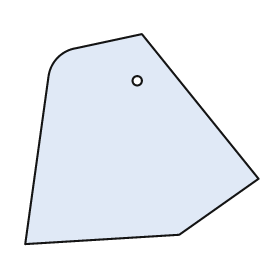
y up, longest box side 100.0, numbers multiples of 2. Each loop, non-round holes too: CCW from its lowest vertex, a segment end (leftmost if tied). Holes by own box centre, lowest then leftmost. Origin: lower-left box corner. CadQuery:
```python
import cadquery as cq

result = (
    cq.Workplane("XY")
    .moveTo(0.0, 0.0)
    .lineTo(66.0, 4.0)
    .lineTo(100.0, 28.0)
    .lineTo(50.0, 90.0)
    .lineTo(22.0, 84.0)
    .threePointArc((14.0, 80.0), (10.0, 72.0))
    .close()
    .moveTo(48.0, 70.0)
    .circle(2.0)
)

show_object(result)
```